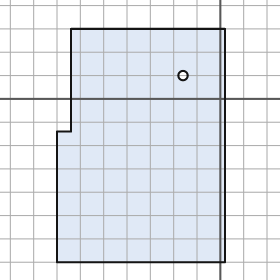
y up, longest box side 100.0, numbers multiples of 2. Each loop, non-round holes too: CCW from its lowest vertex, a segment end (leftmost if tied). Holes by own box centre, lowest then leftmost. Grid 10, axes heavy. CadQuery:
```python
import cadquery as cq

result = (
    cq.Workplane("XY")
    .moveTo(-70.0, -70.0)
    .lineTo(2.0, -70.0)
    .lineTo(2.0, 30.0)
    .lineTo(-64.0, 30.0)
    .lineTo(-64.0, -14.0)
    .lineTo(-70.0, -14.0)
    .close()
    .moveTo(-16.0, 10.0)
    .circle(2.0)
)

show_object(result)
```